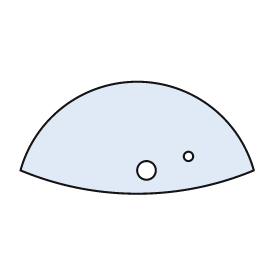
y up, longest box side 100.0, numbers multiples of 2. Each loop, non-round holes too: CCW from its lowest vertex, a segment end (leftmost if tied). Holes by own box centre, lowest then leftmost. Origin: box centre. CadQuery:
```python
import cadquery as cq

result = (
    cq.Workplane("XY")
    .moveTo(-50.0, -14.0)
    .threePointArc((0.0, -24.0), (50.0, -14.0))
    .threePointArc((0.0, 24.0), (-50.0, -14.0))
    .close()
    .moveTo(4.0, -14.0)
    .circle(4.0)
    .moveTo(22.0, -8.0)
    .circle(2.0)
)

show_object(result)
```